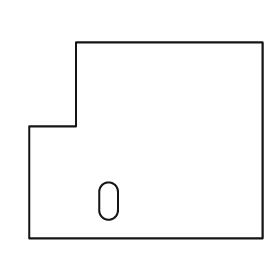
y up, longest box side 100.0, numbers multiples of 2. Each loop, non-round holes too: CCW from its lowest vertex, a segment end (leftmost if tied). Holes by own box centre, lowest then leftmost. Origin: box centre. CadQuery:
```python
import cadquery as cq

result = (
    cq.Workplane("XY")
    .moveTo(-50.0, -42.0)
    .lineTo(50.0, -42.0)
    .lineTo(50.0, 42.0)
    .lineTo(-30.0, 42.0)
    .lineTo(-30.0, 6.0)
    .lineTo(-50.0, 6.0)
    .close()
    .moveTo(-20.0, -30.0)
    .threePointArc((-16.0, -34.0), (-12.0, -30.0))
    .lineTo(-12.0, -22.0)
    .threePointArc((-16.0, -18.0), (-20.0, -22.0))
    .close()
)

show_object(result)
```